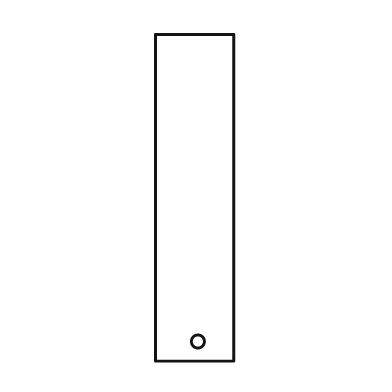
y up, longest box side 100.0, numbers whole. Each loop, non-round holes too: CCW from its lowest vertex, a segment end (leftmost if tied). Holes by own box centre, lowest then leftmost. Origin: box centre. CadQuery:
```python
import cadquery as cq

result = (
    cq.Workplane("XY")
    .moveTo(-12.0, -50.0)
    .lineTo(12.0, -50.0)
    .lineTo(12.0, 50.0)
    .lineTo(-12.0, 50.0)
    .close()
    .moveTo(1.0, -44.0)
    .circle(2.0)
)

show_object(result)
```